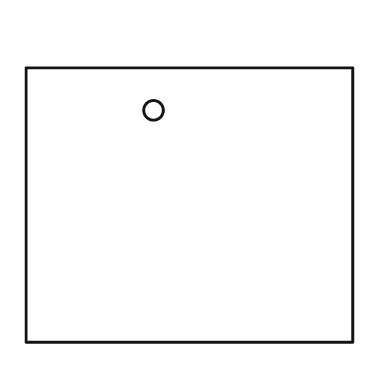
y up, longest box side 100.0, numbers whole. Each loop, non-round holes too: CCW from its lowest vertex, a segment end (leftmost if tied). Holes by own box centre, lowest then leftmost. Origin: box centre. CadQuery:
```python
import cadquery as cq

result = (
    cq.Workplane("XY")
    .moveTo(-50.0, -42.0)
    .lineTo(50.0, -42.0)
    .lineTo(50.0, 42.0)
    .lineTo(-50.0, 42.0)
    .close()
    .moveTo(-11.0, 29.0)
    .circle(3.0)
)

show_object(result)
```